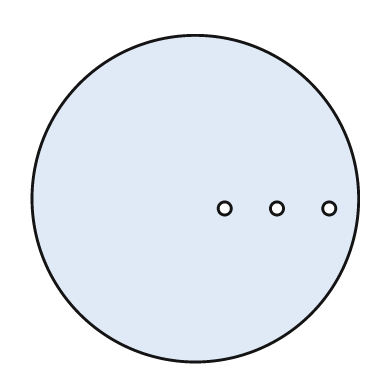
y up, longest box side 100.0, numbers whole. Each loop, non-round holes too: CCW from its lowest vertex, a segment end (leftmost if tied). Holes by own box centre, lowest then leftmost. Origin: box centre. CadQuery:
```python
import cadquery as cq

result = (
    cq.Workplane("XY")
    .moveTo(0.0, 0.0)
    .circle(50.0)
    .moveTo(9.0, -3.0)
    .circle(2.0)
    .moveTo(25.0, -3.0)
    .circle(2.0)
    .moveTo(41.0, -3.0)
    .circle(2.0)
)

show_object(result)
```